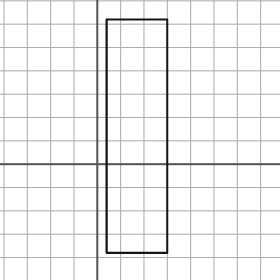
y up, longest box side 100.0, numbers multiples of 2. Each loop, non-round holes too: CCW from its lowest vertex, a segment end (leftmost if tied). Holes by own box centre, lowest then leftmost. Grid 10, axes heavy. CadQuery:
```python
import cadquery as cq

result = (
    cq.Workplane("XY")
    .moveTo(4.0, -38.0)
    .lineTo(30.0, -38.0)
    .lineTo(30.0, 62.0)
    .lineTo(4.0, 62.0)
    .close()
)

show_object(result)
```